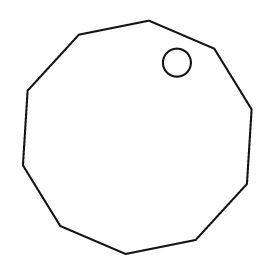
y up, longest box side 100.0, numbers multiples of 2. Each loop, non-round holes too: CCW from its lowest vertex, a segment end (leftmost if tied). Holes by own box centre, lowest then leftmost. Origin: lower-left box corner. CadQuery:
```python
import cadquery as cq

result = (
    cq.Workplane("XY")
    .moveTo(44.0, 0.0)
    .lineTo(74.0, 6.0)
    .lineTo(96.0, 30.0)
    .lineTo(98.0, 62.0)
    .lineTo(82.0, 88.0)
    .lineTo(54.0, 100.0)
    .lineTo(24.0, 94.0)
    .lineTo(2.0, 70.0)
    .lineTo(0.0, 38.0)
    .lineTo(16.0, 12.0)
    .close()
    .moveTo(66.0, 82.0)
    .circle(6.0)
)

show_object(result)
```